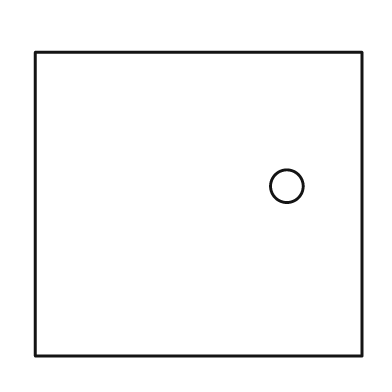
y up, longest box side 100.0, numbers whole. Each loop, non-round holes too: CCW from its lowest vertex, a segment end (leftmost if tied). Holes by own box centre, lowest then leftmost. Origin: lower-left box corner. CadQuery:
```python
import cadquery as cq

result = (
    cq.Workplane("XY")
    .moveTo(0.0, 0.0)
    .lineTo(100.0, 0.0)
    .lineTo(100.0, 93.0)
    .lineTo(0.0, 93.0)
    .close()
    .moveTo(77.0, 52.0)
    .circle(5.0)
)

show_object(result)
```